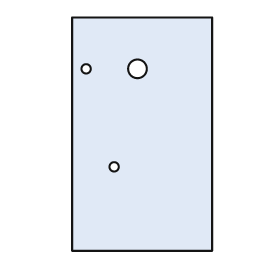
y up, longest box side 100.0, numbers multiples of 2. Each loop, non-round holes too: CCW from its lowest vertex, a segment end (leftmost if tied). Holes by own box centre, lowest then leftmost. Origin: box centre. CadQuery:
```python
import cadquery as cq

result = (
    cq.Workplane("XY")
    .moveTo(-30.0, -50.0)
    .lineTo(30.0, -50.0)
    .lineTo(30.0, 50.0)
    .lineTo(-30.0, 50.0)
    .close()
    .moveTo(-12.0, -14.0)
    .circle(2.0)
    .moveTo(-24.0, 28.0)
    .circle(2.0)
    .moveTo(-2.0, 28.0)
    .circle(4.0)
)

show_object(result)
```